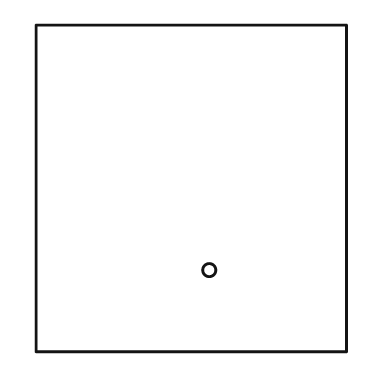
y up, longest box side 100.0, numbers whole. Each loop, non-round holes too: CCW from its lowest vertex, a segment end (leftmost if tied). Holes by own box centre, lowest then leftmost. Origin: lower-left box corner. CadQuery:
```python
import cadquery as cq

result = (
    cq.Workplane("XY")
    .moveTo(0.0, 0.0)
    .lineTo(95.0, 0.0)
    .lineTo(95.0, 100.0)
    .lineTo(0.0, 100.0)
    .close()
    .moveTo(53.0, 25.0)
    .circle(2.0)
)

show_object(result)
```